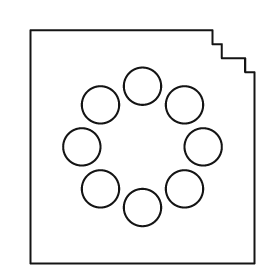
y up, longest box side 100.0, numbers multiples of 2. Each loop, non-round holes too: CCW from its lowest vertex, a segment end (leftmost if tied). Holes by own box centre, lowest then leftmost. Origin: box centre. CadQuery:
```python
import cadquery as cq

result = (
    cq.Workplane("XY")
    .moveTo(-48.0, -50.0)
    .lineTo(48.0, -50.0)
    .lineTo(48.0, 32.0)
    .lineTo(44.0, 32.0)
    .lineTo(44.0, 38.0)
    .lineTo(34.0, 38.0)
    .lineTo(34.0, 44.0)
    .lineTo(30.0, 44.0)
    .lineTo(30.0, 50.0)
    .lineTo(-48.0, 50.0)
    .close()
    .moveTo(0.0, -26.0)
    .circle(8.0)
    .moveTo(-18.0, -18.0)
    .circle(8.0)
    .moveTo(18.0, -18.0)
    .circle(8.0)
    .moveTo(-26.0, 0.0)
    .circle(8.0)
    .moveTo(26.0, 0.0)
    .circle(8.0)
    .moveTo(-18.0, 18.0)
    .circle(8.0)
    .moveTo(18.0, 18.0)
    .circle(8.0)
    .moveTo(0.0, 26.0)
    .circle(8.0)
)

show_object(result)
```